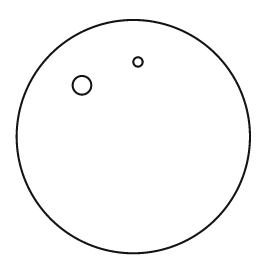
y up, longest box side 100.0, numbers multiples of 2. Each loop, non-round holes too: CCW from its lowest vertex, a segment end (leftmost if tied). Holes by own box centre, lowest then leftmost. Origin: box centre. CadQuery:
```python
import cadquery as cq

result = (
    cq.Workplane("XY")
    .moveTo(0.0, 0.0)
    .circle(50.0)
    .moveTo(-22.0, 22.0)
    .circle(4.0)
    .moveTo(2.0, 32.0)
    .circle(2.0)
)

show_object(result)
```